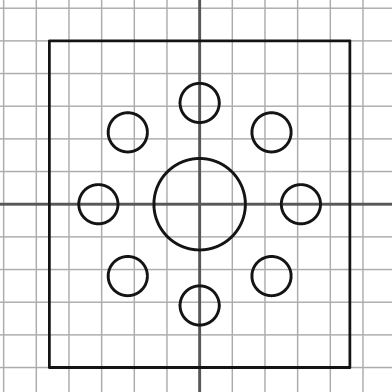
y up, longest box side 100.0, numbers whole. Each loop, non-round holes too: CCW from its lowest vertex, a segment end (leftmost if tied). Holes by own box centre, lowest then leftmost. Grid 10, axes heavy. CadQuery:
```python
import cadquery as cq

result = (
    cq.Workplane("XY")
    .moveTo(-46.0, -50.0)
    .lineTo(46.0, -50.0)
    .lineTo(46.0, 50.0)
    .lineTo(-46.0, 50.0)
    .close()
    .moveTo(0.0, -31.0)
    .circle(6.0)
    .moveTo(-22.0, -22.0)
    .circle(6.0)
    .moveTo(22.0, -22.0)
    .circle(6.0)
    .moveTo(-31.0, 0.0)
    .circle(6.0)
    .moveTo(0.0, 0.0)
    .circle(14.0)
    .moveTo(31.0, 0.0)
    .circle(6.0)
    .moveTo(-22.0, 22.0)
    .circle(6.0)
    .moveTo(22.0, 22.0)
    .circle(6.0)
    .moveTo(0.0, 31.0)
    .circle(6.0)
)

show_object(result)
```